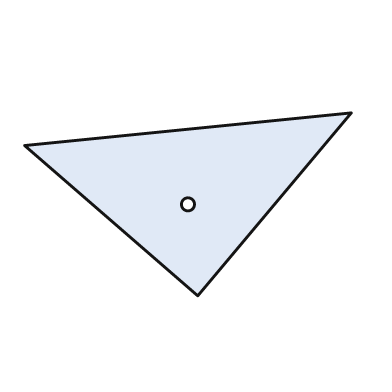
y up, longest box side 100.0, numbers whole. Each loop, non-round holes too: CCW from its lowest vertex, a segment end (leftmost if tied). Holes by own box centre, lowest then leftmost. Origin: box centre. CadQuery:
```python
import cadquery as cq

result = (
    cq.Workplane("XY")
    .moveTo(3.0, -28.0)
    .lineTo(50.0, 28.0)
    .lineTo(-50.0, 18.0)
    .close()
    .moveTo(0.0, 0.0)
    .circle(2.0)
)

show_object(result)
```